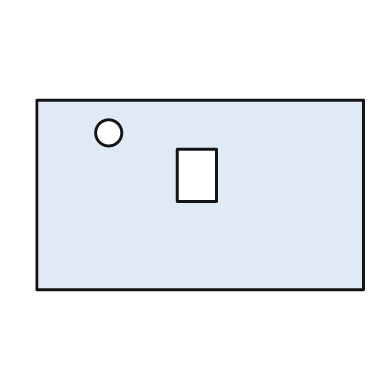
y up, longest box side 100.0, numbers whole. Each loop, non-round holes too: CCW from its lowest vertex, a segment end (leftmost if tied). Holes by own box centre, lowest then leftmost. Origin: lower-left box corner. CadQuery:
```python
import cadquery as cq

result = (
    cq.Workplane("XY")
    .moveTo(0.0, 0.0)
    .lineTo(100.0, 0.0)
    .lineTo(100.0, 58.0)
    .lineTo(0.0, 58.0)
    .close()
    .moveTo(43.0, 27.0)
    .lineTo(55.0, 27.0)
    .lineTo(55.0, 43.0)
    .lineTo(43.0, 43.0)
    .close()
    .moveTo(22.0, 48.0)
    .circle(4.0)
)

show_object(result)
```